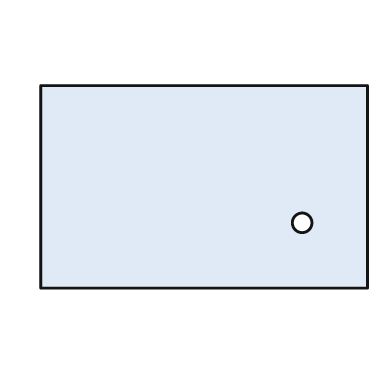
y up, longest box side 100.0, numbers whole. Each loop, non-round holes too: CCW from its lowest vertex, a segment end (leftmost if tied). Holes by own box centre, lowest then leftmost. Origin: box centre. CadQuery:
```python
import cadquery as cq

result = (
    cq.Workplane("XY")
    .moveTo(-50.0, -31.0)
    .lineTo(50.0, -31.0)
    .lineTo(50.0, 31.0)
    .lineTo(-50.0, 31.0)
    .close()
    .moveTo(30.0, -11.0)
    .circle(3.0)
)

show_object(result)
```